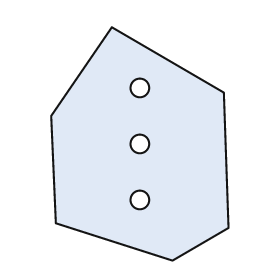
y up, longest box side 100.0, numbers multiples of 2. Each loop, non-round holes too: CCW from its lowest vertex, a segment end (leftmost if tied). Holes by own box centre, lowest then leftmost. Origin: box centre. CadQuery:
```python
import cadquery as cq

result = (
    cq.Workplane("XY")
    .moveTo(14.0, -50.0)
    .lineTo(38.0, -36.0)
    .lineTo(36.0, 22.0)
    .lineTo(-12.0, 50.0)
    .lineTo(-38.0, 12.0)
    .lineTo(-36.0, -34.0)
    .close()
    .moveTo(0.0, -24.0)
    .circle(4.0)
    .moveTo(0.0, 0.0)
    .circle(4.0)
    .moveTo(0.0, 24.0)
    .circle(4.0)
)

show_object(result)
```